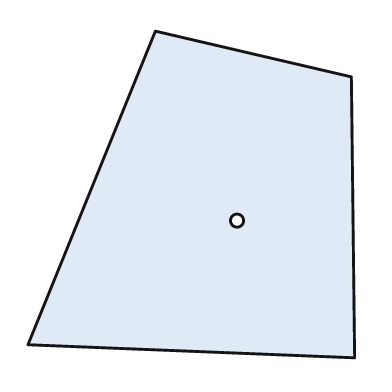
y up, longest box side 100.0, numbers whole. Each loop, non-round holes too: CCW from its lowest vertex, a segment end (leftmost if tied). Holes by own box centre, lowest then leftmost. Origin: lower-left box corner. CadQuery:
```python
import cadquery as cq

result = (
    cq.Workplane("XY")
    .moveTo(100.0, 0.0)
    .lineTo(99.0, 86.0)
    .lineTo(39.0, 100.0)
    .lineTo(0.0, 4.0)
    .close()
    .moveTo(64.0, 42.0)
    .circle(2.0)
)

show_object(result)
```